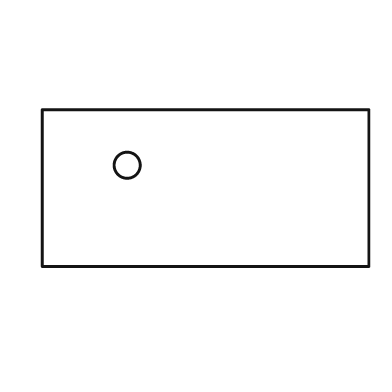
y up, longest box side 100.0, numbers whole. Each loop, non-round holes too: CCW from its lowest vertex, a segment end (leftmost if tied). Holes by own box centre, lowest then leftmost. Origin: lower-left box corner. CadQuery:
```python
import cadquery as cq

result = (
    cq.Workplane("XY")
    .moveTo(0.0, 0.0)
    .lineTo(100.0, 0.0)
    .lineTo(100.0, 48.0)
    .lineTo(0.0, 48.0)
    .close()
    .moveTo(26.0, 31.0)
    .circle(4.0)
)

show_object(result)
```